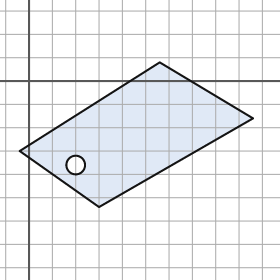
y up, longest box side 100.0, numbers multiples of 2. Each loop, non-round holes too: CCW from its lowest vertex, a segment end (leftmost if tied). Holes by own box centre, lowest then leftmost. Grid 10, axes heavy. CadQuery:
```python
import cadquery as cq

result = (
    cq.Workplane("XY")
    .moveTo(30.0, -54.0)
    .lineTo(96.0, -16.0)
    .lineTo(56.0, 8.0)
    .lineTo(-4.0, -30.0)
    .close()
    .moveTo(20.0, -36.0)
    .circle(4.0)
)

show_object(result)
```